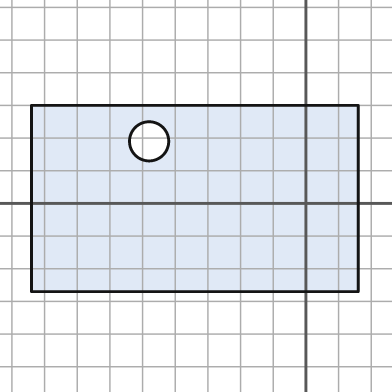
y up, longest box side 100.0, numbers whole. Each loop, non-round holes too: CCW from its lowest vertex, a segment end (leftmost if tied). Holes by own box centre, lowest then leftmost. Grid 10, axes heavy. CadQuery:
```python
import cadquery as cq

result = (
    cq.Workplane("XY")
    .moveTo(-84.0, -27.0)
    .lineTo(16.0, -27.0)
    .lineTo(16.0, 30.0)
    .lineTo(-84.0, 30.0)
    .close()
    .moveTo(-48.0, 19.0)
    .circle(6.0)
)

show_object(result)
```